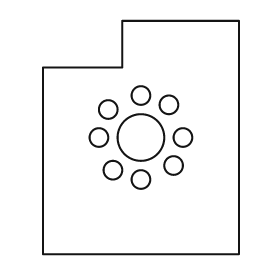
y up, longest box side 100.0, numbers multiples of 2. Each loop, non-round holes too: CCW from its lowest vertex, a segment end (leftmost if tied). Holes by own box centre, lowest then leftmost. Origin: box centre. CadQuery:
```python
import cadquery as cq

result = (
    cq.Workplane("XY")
    .moveTo(-42.0, -50.0)
    .lineTo(42.0, -50.0)
    .lineTo(42.0, 50.0)
    .lineTo(-8.0, 50.0)
    .lineTo(-8.0, 30.0)
    .lineTo(-42.0, 30.0)
    .close()
    .moveTo(0.0, -18.0)
    .circle(4.0)
    .moveTo(-12.0, -14.0)
    .circle(4.0)
    .moveTo(14.0, -12.0)
    .circle(4.0)
    .moveTo(-18.0, 0.0)
    .circle(4.0)
    .moveTo(0.0, 0.0)
    .circle(10.0)
    .moveTo(18.0, 0.0)
    .circle(4.0)
    .moveTo(-14.0, 12.0)
    .circle(4.0)
    .moveTo(12.0, 14.0)
    .circle(4.0)
    .moveTo(0.0, 18.0)
    .circle(4.0)
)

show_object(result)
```